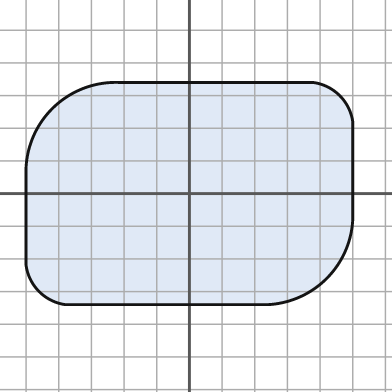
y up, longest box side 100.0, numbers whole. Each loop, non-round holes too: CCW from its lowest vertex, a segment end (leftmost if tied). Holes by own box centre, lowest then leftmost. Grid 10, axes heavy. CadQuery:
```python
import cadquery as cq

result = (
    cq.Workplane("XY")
    .moveTo(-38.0, -34.0)
    .lineTo(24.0, -34.0)
    .threePointArc((42.0, -26.0), (50.0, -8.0))
    .lineTo(50.0, 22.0)
    .threePointArc((46.0, 30.0), (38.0, 34.0))
    .lineTo(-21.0, 34.0)
    .threePointArc((-42.0, 26.0), (-50.0, 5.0))
    .lineTo(-50.0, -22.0)
    .threePointArc((-46.0, -30.0), (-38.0, -34.0))
    .close()
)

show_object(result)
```